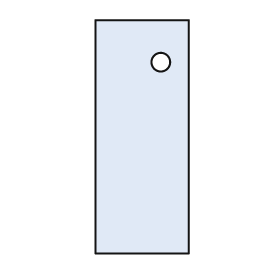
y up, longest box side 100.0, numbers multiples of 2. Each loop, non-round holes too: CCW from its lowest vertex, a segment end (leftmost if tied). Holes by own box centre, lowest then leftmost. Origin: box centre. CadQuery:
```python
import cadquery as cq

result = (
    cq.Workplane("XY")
    .moveTo(-20.0, -50.0)
    .lineTo(20.0, -50.0)
    .lineTo(20.0, 50.0)
    .lineTo(-20.0, 50.0)
    .close()
    .moveTo(8.0, 32.0)
    .circle(4.0)
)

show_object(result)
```